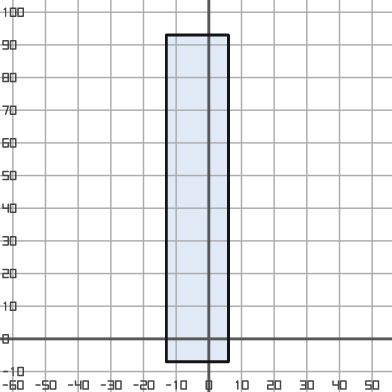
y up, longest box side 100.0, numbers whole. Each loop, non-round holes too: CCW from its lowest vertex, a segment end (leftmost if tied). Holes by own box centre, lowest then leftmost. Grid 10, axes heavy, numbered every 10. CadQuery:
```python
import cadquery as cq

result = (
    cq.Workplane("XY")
    .moveTo(-13.0, -7.0)
    .lineTo(6.0, -7.0)
    .lineTo(6.0, 93.0)
    .lineTo(-13.0, 93.0)
    .close()
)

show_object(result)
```